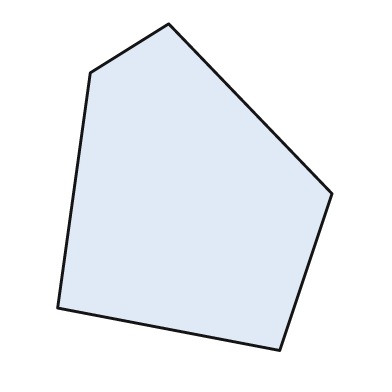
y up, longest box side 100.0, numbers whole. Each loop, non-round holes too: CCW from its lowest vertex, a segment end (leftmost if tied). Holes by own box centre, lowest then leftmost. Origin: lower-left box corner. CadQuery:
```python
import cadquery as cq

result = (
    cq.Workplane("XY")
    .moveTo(68.0, 0.0)
    .lineTo(84.0, 48.0)
    .lineTo(34.0, 100.0)
    .lineTo(10.0, 85.0)
    .lineTo(0.0, 13.0)
    .close()
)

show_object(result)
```